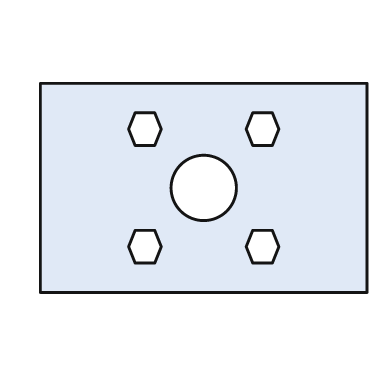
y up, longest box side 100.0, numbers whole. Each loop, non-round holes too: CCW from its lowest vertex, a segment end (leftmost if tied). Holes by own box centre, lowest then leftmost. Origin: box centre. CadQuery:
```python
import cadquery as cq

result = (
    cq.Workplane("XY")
    .moveTo(-50.0, -32.0)
    .lineTo(50.0, -32.0)
    .lineTo(50.0, 32.0)
    .lineTo(-50.0, 32.0)
    .close()
    .moveTo(-21.0, -23.0)
    .lineTo(-15.0, -23.0)
    .lineTo(-13.0, -18.0)
    .lineTo(-15.0, -13.0)
    .lineTo(-21.0, -13.0)
    .lineTo(-23.0, -18.0)
    .close()
    .moveTo(15.0, -23.0)
    .lineTo(21.0, -23.0)
    .lineTo(23.0, -18.0)
    .lineTo(21.0, -13.0)
    .lineTo(15.0, -13.0)
    .lineTo(13.0, -18.0)
    .close()
    .moveTo(0.0, 0.0)
    .circle(10.0)
    .moveTo(-21.0, 13.0)
    .lineTo(-15.0, 13.0)
    .lineTo(-13.0, 18.0)
    .lineTo(-15.0, 23.0)
    .lineTo(-21.0, 23.0)
    .lineTo(-23.0, 18.0)
    .close()
    .moveTo(15.0, 13.0)
    .lineTo(21.0, 13.0)
    .lineTo(23.0, 18.0)
    .lineTo(21.0, 23.0)
    .lineTo(15.0, 23.0)
    .lineTo(13.0, 18.0)
    .close()
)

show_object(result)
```